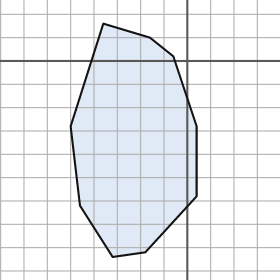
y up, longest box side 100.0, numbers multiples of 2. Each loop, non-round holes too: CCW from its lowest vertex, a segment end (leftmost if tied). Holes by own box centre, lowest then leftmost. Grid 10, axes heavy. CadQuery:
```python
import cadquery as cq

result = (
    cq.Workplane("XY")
    .moveTo(-32.0, -84.0)
    .lineTo(-18.0, -82.0)
    .lineTo(4.0, -58.0)
    .lineTo(4.0, -28.0)
    .lineTo(-6.0, 2.0)
    .lineTo(-16.0, 10.0)
    .lineTo(-36.0, 16.0)
    .lineTo(-50.0, -28.0)
    .lineTo(-46.0, -62.0)
    .close()
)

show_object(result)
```